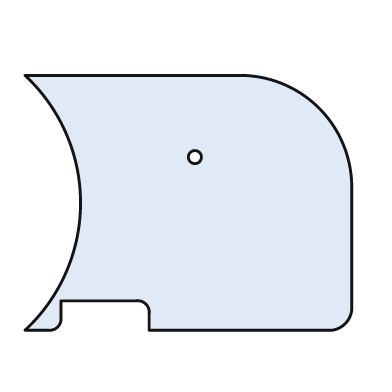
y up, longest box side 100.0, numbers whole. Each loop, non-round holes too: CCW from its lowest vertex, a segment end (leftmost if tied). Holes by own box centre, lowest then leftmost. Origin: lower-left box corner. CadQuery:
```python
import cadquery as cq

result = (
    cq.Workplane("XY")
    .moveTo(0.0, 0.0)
    .lineTo(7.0, 0.0)
    .threePointArc((10.0, 1.0), (11.0, 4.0))
    .lineTo(11.0, 9.0)
    .lineTo(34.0, 9.0)
    .threePointArc((37.0, 8.0), (38.0, 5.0))
    .lineTo(38.0, 0.0)
    .lineTo(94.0, 0.0)
    .threePointArc((98.0, 2.0), (100.0, 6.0))
    .lineTo(100.0, 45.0)
    .threePointArc((90.0, 68.0), (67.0, 78.0))
    .lineTo(0.0, 78.0)
    .threePointArc((17.0, 39.0), (0.0, 0.0))
    .close()
    .moveTo(52.0, 53.0)
    .circle(2.0)
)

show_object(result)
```